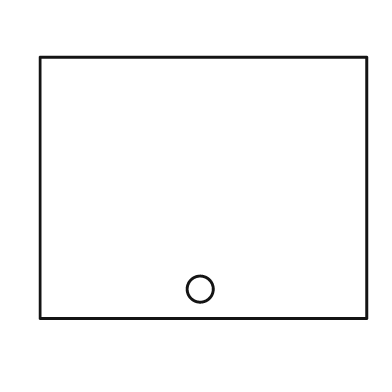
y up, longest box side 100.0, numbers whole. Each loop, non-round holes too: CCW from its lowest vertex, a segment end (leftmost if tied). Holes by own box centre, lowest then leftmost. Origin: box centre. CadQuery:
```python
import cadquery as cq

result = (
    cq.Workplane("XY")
    .moveTo(-50.0, -40.0)
    .lineTo(50.0, -40.0)
    .lineTo(50.0, 40.0)
    .lineTo(-50.0, 40.0)
    .close()
    .moveTo(-1.0, -31.0)
    .circle(4.0)
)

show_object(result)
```